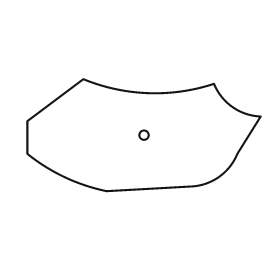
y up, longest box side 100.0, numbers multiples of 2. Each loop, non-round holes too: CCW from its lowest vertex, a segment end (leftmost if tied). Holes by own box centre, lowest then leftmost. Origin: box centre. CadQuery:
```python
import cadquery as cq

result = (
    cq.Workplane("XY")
    .moveTo(-16.0, -24.0)
    .lineTo(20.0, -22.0)
    .threePointArc((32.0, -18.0), (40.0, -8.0))
    .lineTo(50.0, 8.0)
    .threePointArc((38.0, 12.0), (30.0, 22.0))
    .threePointArc((2.0, 18.0), (-26.0, 24.0))
    .lineTo(-50.0, 6.0)
    .lineTo(-50.0, -8.0)
    .threePointArc((-34.0, -18.0), (-16.0, -24.0))
    .close()
    .moveTo(0.0, 0.0)
    .circle(2.0)
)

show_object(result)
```